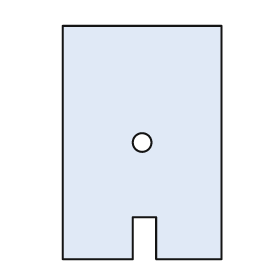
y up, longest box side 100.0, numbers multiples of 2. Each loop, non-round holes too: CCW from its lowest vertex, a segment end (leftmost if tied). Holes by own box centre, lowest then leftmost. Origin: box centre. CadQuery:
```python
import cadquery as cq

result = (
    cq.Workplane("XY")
    .moveTo(-34.0, -50.0)
    .lineTo(-4.0, -50.0)
    .lineTo(-4.0, -32.0)
    .lineTo(6.0, -32.0)
    .lineTo(6.0, -50.0)
    .lineTo(34.0, -50.0)
    .lineTo(34.0, 50.0)
    .lineTo(-34.0, 50.0)
    .close()
    .moveTo(0.0, 0.0)
    .circle(4.0)
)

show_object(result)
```